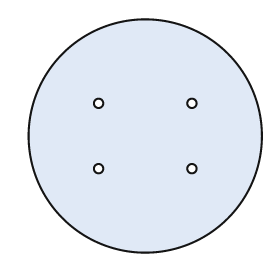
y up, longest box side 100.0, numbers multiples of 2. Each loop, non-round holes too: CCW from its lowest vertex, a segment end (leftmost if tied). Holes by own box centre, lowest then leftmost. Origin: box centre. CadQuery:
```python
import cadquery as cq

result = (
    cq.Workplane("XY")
    .moveTo(0.0, 0.0)
    .circle(50.0)
    .moveTo(-20.0, -14.0)
    .circle(2.0)
    .moveTo(20.0, -14.0)
    .circle(2.0)
    .moveTo(-20.0, 14.0)
    .circle(2.0)
    .moveTo(20.0, 14.0)
    .circle(2.0)
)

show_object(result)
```